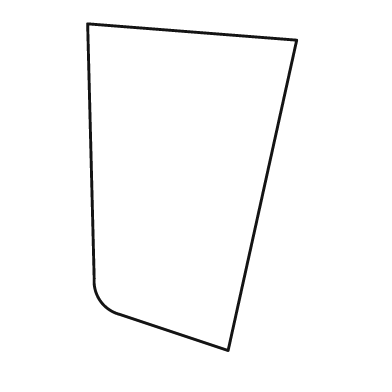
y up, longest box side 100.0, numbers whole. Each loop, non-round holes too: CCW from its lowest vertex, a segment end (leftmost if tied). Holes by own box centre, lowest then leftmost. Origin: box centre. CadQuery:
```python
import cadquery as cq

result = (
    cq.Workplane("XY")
    .moveTo(11.0, -50.0)
    .lineTo(32.0, 45.0)
    .lineTo(-32.0, 50.0)
    .lineTo(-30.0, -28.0)
    .threePointArc((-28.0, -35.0), (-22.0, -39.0))
    .close()
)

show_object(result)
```